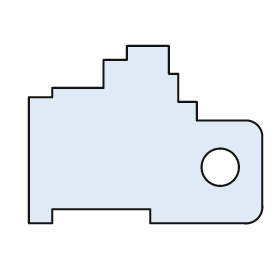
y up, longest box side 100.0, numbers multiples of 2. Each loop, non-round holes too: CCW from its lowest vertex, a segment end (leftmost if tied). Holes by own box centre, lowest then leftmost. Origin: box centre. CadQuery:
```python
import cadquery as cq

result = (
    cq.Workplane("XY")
    .moveTo(-50.0, -38.0)
    .lineTo(-40.0, -38.0)
    .lineTo(-40.0, -32.0)
    .lineTo(2.0, -32.0)
    .lineTo(2.0, -38.0)
    .lineTo(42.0, -38.0)
    .threePointArc((48.0, -36.0), (50.0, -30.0))
    .lineTo(50.0, 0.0)
    .threePointArc((48.0, 4.0), (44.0, 6.0))
    .lineTo(22.0, 6.0)
    .lineTo(22.0, 14.0)
    .lineTo(14.0, 14.0)
    .lineTo(14.0, 26.0)
    .lineTo(10.0, 26.0)
    .lineTo(10.0, 38.0)
    .lineTo(-8.0, 38.0)
    .lineTo(-8.0, 32.0)
    .lineTo(-18.0, 32.0)
    .lineTo(-18.0, 20.0)
    .lineTo(-40.0, 20.0)
    .lineTo(-40.0, 16.0)
    .lineTo(-50.0, 16.0)
    .close()
    .moveTo(32.0, -14.0)
    .circle(8.0)
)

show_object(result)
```